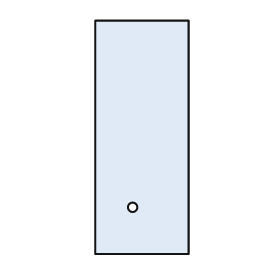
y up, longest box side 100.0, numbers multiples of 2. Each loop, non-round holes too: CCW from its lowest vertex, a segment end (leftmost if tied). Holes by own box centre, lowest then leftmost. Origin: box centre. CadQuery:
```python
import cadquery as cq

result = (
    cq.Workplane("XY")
    .moveTo(-20.0, -50.0)
    .lineTo(20.0, -50.0)
    .lineTo(20.0, 50.0)
    .lineTo(-20.0, 50.0)
    .close()
    .moveTo(-4.0, -30.0)
    .circle(2.0)
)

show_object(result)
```